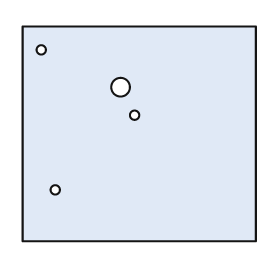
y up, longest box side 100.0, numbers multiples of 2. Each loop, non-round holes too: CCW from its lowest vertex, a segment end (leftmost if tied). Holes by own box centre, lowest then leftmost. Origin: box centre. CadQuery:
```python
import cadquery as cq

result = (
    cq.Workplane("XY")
    .moveTo(-50.0, -46.0)
    .lineTo(50.0, -46.0)
    .lineTo(50.0, 46.0)
    .lineTo(-50.0, 46.0)
    .close()
    .moveTo(-36.0, -24.0)
    .circle(2.0)
    .moveTo(-2.0, 8.0)
    .circle(2.0)
    .moveTo(-8.0, 20.0)
    .circle(4.0)
    .moveTo(-42.0, 36.0)
    .circle(2.0)
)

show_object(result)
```